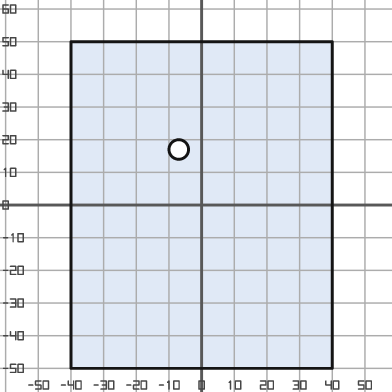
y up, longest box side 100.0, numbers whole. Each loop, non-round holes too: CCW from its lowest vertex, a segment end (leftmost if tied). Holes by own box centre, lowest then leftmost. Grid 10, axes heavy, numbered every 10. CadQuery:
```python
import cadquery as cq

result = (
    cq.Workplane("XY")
    .moveTo(-40.0, -50.0)
    .lineTo(40.0, -50.0)
    .lineTo(40.0, 50.0)
    .lineTo(-40.0, 50.0)
    .close()
    .moveTo(-7.0, 17.0)
    .circle(3.0)
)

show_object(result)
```